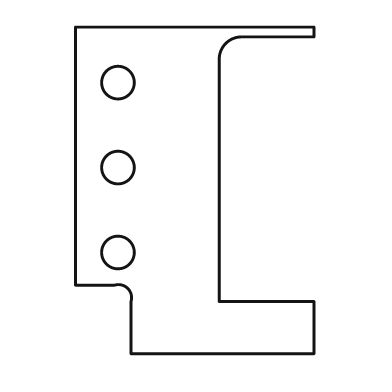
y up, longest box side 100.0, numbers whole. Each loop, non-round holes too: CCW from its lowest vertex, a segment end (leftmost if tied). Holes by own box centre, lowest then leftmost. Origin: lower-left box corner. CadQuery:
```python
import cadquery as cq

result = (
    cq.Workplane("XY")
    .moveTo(17.0, 0.0)
    .lineTo(73.0, 0.0)
    .lineTo(73.0, 16.0)
    .lineTo(44.0, 16.0)
    .lineTo(44.0, 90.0)
    .threePointArc((46.0, 95.0), (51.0, 97.0))
    .lineTo(73.0, 97.0)
    .lineTo(73.0, 100.0)
    .lineTo(0.0, 100.0)
    .lineTo(0.0, 21.0)
    .lineTo(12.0, 21.0)
    .threePointArc((16.0, 20.0), (17.0, 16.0))
    .close()
    .moveTo(13.0, 31.0)
    .circle(5.0)
    .moveTo(13.0, 57.0)
    .circle(5.0)
    .moveTo(13.0, 83.0)
    .circle(5.0)
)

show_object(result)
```